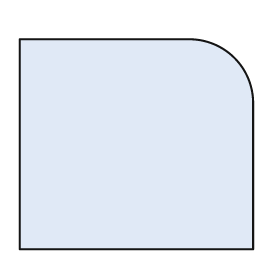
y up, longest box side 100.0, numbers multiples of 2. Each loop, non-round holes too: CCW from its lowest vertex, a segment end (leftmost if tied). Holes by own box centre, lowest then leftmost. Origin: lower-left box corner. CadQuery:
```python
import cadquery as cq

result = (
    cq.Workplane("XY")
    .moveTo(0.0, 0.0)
    .lineTo(100.0, 0.0)
    .lineTo(100.0, 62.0)
    .threePointArc((92.0, 82.0), (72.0, 90.0))
    .lineTo(0.0, 90.0)
    .close()
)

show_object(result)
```